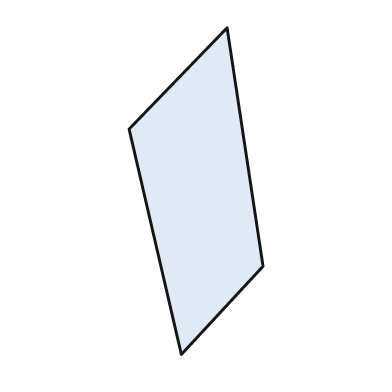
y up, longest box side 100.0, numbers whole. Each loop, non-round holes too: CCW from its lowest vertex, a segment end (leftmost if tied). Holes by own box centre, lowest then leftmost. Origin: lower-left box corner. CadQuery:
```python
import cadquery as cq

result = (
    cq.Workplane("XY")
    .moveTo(16.0, 0.0)
    .lineTo(41.0, 27.0)
    .lineTo(30.0, 100.0)
    .lineTo(0.0, 69.0)
    .close()
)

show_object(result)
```